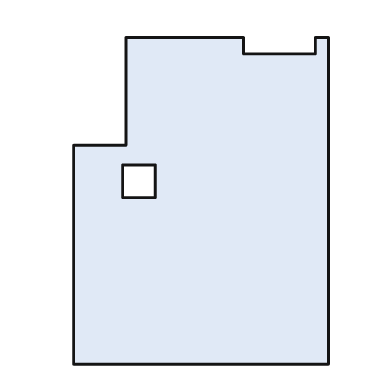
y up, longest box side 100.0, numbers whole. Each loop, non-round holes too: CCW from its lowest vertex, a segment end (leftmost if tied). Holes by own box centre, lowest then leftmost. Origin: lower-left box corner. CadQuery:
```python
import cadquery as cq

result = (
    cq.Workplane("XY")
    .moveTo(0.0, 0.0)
    .lineTo(78.0, 0.0)
    .lineTo(78.0, 100.0)
    .lineTo(74.0, 100.0)
    .lineTo(74.0, 95.0)
    .lineTo(52.0, 95.0)
    .lineTo(52.0, 100.0)
    .lineTo(16.0, 100.0)
    .lineTo(16.0, 67.0)
    .lineTo(0.0, 67.0)
    .close()
    .moveTo(15.0, 51.0)
    .lineTo(25.0, 51.0)
    .lineTo(25.0, 61.0)
    .lineTo(15.0, 61.0)
    .close()
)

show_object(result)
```